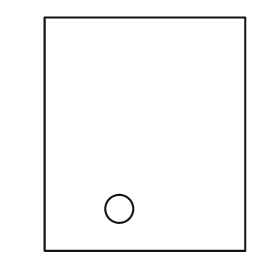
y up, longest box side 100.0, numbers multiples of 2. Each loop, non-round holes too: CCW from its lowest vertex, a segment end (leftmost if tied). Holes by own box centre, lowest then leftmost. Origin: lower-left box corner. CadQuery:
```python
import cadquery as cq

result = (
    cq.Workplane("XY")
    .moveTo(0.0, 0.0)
    .lineTo(86.0, 0.0)
    .lineTo(86.0, 100.0)
    .lineTo(0.0, 100.0)
    .close()
    .moveTo(32.0, 18.0)
    .circle(6.0)
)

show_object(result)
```